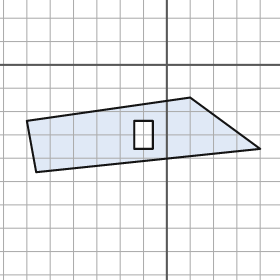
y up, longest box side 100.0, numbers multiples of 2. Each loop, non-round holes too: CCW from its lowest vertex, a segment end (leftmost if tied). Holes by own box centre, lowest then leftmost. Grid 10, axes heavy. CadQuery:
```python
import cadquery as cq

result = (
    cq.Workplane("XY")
    .moveTo(-56.0, -46.0)
    .lineTo(40.0, -36.0)
    .lineTo(10.0, -14.0)
    .lineTo(-60.0, -24.0)
    .close()
    .moveTo(-14.0, -36.0)
    .lineTo(-6.0, -36.0)
    .lineTo(-6.0, -24.0)
    .lineTo(-14.0, -24.0)
    .close()
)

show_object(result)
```